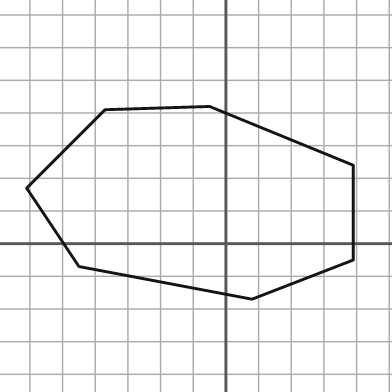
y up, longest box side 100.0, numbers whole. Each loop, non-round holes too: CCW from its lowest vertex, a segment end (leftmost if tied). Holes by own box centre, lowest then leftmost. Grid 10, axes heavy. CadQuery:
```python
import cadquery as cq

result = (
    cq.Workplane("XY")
    .moveTo(8.0, -17.0)
    .lineTo(39.0, -5.0)
    .lineTo(39.0, 24.0)
    .lineTo(-5.0, 42.0)
    .lineTo(-37.0, 41.0)
    .lineTo(-61.0, 17.0)
    .lineTo(-45.0, -7.0)
    .close()
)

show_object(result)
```